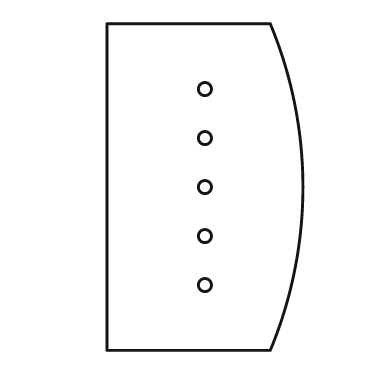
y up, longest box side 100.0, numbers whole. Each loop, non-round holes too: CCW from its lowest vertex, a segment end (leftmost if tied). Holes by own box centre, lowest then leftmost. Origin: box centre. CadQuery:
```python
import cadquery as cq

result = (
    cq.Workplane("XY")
    .moveTo(-30.0, -50.0)
    .lineTo(20.0, -50.0)
    .threePointArc((30.0, 0.0), (20.0, 50.0))
    .lineTo(-30.0, 50.0)
    .close()
    .moveTo(0.0, -30.0)
    .circle(2.0)
    .moveTo(0.0, -15.0)
    .circle(2.0)
    .moveTo(0.0, 0.0)
    .circle(2.0)
    .moveTo(0.0, 15.0)
    .circle(2.0)
    .moveTo(0.0, 30.0)
    .circle(2.0)
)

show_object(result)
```